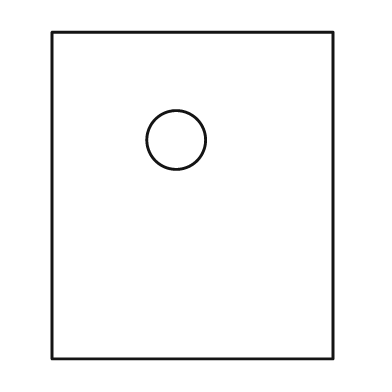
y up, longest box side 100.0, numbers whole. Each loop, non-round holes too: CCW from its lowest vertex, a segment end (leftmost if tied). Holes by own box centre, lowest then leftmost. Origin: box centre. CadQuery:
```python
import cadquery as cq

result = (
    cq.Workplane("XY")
    .moveTo(-43.0, -50.0)
    .lineTo(43.0, -50.0)
    .lineTo(43.0, 50.0)
    .lineTo(-43.0, 50.0)
    .close()
    .moveTo(-5.0, 17.0)
    .circle(9.0)
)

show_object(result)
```